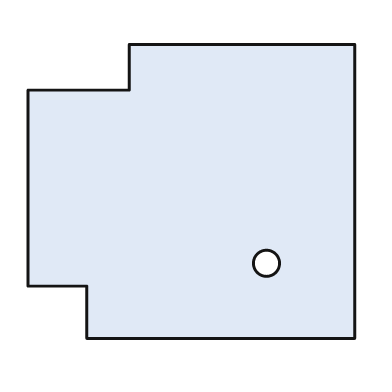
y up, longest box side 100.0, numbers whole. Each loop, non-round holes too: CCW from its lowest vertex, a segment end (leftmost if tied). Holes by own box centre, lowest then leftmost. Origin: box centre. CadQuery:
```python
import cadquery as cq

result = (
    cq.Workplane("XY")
    .moveTo(-32.0, -45.0)
    .lineTo(50.0, -45.0)
    .lineTo(50.0, 45.0)
    .lineTo(-19.0, 45.0)
    .lineTo(-19.0, 31.0)
    .lineTo(-50.0, 31.0)
    .lineTo(-50.0, -29.0)
    .lineTo(-32.0, -29.0)
    .close()
    .moveTo(23.0, -22.0)
    .circle(4.0)
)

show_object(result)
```